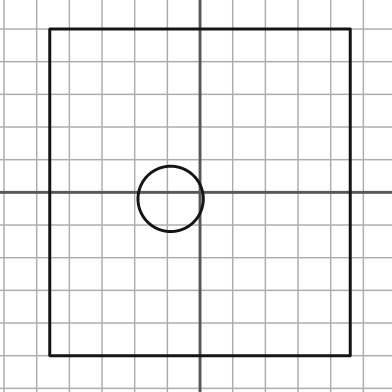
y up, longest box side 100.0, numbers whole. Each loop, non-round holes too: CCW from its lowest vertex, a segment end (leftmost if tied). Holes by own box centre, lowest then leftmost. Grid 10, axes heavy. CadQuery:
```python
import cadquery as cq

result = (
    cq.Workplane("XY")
    .moveTo(-46.0, -50.0)
    .lineTo(46.0, -50.0)
    .lineTo(46.0, 50.0)
    .lineTo(-46.0, 50.0)
    .close()
    .moveTo(-9.0, -2.0)
    .circle(10.0)
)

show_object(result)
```